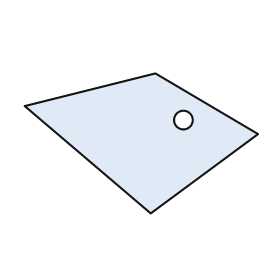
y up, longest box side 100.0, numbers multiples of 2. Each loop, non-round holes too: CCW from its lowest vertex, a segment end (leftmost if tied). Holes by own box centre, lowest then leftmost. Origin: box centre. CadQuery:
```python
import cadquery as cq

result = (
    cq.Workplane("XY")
    .moveTo(4.0, -30.0)
    .lineTo(50.0, 4.0)
    .lineTo(6.0, 30.0)
    .lineTo(-50.0, 16.0)
    .close()
    .moveTo(18.0, 10.0)
    .circle(4.0)
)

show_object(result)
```